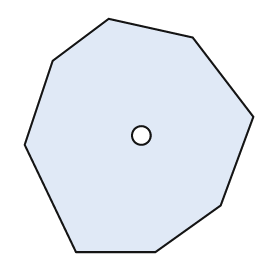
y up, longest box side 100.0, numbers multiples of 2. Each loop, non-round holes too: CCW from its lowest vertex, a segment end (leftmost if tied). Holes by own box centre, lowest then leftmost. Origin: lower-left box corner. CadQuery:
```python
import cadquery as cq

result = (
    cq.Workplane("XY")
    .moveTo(22.0, 0.0)
    .lineTo(56.0, 0.0)
    .lineTo(84.0, 20.0)
    .lineTo(98.0, 58.0)
    .lineTo(72.0, 92.0)
    .lineTo(36.0, 100.0)
    .lineTo(12.0, 82.0)
    .lineTo(0.0, 46.0)
    .close()
    .moveTo(50.0, 50.0)
    .circle(4.0)
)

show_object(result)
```